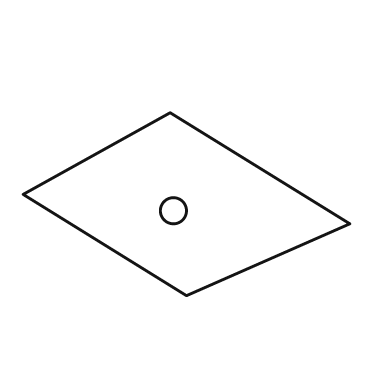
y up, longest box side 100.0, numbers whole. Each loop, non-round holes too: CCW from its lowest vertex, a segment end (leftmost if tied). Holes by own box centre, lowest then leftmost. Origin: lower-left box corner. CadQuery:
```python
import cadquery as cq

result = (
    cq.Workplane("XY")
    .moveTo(50.0, 0.0)
    .lineTo(100.0, 22.0)
    .lineTo(45.0, 56.0)
    .lineTo(0.0, 31.0)
    .close()
    .moveTo(46.0, 26.0)
    .circle(4.0)
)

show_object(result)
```